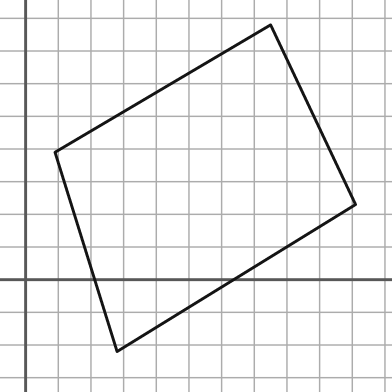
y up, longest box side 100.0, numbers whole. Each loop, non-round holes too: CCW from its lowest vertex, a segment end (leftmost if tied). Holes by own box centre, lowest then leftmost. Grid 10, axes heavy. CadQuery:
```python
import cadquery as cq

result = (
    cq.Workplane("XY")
    .moveTo(28.0, -22.0)
    .lineTo(101.0, 23.0)
    .lineTo(75.0, 78.0)
    .lineTo(9.0, 39.0)
    .close()
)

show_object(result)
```